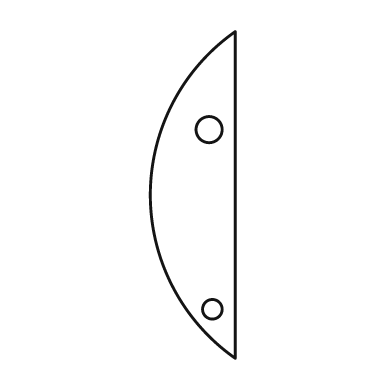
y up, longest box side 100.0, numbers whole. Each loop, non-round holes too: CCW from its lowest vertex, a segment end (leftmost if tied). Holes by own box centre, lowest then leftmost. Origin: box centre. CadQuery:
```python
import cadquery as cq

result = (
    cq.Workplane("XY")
    .moveTo(13.0, -50.0)
    .lineTo(13.0, 50.0)
    .threePointArc((-13.0, 0.0), (13.0, -50.0))
    .close()
    .moveTo(6.0, -35.0)
    .circle(3.0)
    .moveTo(5.0, 20.0)
    .circle(4.0)
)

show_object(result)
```